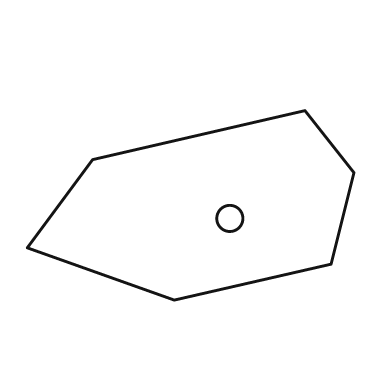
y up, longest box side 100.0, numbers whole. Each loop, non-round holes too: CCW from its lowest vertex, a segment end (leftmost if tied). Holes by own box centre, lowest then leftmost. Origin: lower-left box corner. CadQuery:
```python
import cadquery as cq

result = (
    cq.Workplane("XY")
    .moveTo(45.0, 0.0)
    .lineTo(93.0, 11.0)
    .lineTo(100.0, 39.0)
    .lineTo(85.0, 58.0)
    .lineTo(20.0, 43.0)
    .lineTo(0.0, 16.0)
    .close()
    .moveTo(62.0, 25.0)
    .circle(4.0)
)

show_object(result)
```